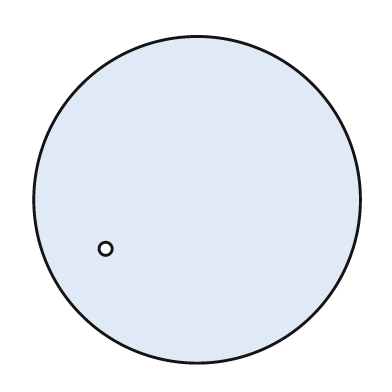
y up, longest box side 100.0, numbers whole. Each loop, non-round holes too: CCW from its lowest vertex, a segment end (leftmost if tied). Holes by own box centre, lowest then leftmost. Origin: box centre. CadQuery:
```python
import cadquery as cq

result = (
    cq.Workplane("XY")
    .moveTo(0.0, 0.0)
    .circle(50.0)
    .moveTo(-28.0, -15.0)
    .circle(2.0)
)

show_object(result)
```